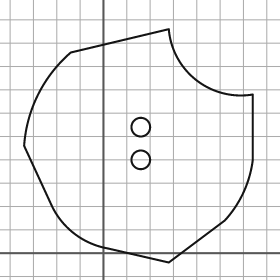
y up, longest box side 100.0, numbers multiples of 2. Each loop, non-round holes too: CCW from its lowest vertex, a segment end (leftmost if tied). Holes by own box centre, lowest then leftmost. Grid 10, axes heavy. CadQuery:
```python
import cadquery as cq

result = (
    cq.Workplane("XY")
    .moveTo(28.0, -4.0)
    .lineTo(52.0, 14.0)
    .threePointArc((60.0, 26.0), (64.0, 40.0))
    .lineTo(64.0, 68.0)
    .threePointArc((40.0, 74.0), (28.0, 96.0))
    .lineTo(-14.0, 86.0)
    .threePointArc((-28.0, 68.0), (-34.0, 46.0))
    .lineTo(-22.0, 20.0)
    .threePointArc((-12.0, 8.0), (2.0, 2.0))
    .close()
    .moveTo(16.0, 40.0)
    .circle(4.0)
    .moveTo(16.0, 54.0)
    .circle(4.0)
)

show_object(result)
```